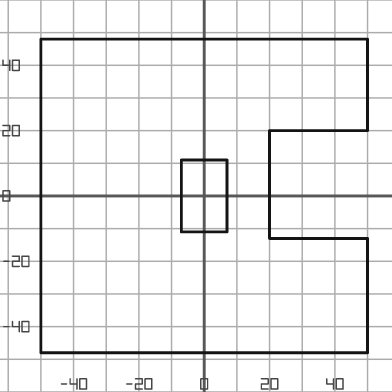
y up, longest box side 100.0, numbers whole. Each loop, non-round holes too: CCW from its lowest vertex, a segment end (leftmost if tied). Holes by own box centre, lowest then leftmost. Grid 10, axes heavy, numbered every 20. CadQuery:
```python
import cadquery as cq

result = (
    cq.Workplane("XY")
    .moveTo(-50.0, -48.0)
    .lineTo(50.0, -48.0)
    .lineTo(50.0, -13.0)
    .lineTo(20.0, -13.0)
    .lineTo(20.0, 20.0)
    .lineTo(50.0, 20.0)
    .lineTo(50.0, 48.0)
    .lineTo(-50.0, 48.0)
    .close()
    .moveTo(-7.0, -11.0)
    .lineTo(7.0, -11.0)
    .lineTo(7.0, 11.0)
    .lineTo(-7.0, 11.0)
    .close()
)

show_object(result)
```